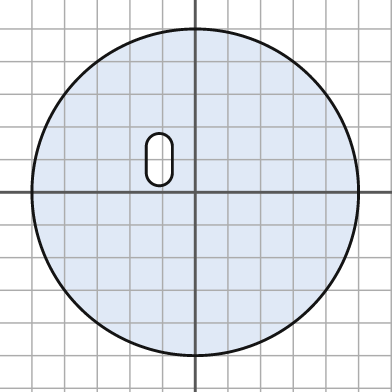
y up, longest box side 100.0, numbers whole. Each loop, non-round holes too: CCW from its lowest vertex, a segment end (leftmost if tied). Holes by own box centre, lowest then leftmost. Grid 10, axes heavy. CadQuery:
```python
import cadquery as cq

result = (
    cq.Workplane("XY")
    .moveTo(0.0, 0.0)
    .circle(50.0)
    .moveTo(-15.0, 6.0)
    .threePointArc((-11.0, 2.0), (-7.0, 6.0))
    .lineTo(-7.0, 14.0)
    .threePointArc((-11.0, 18.0), (-15.0, 14.0))
    .close()
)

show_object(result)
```